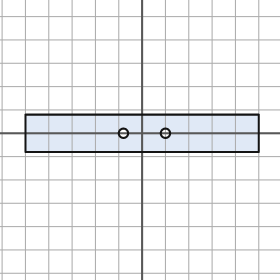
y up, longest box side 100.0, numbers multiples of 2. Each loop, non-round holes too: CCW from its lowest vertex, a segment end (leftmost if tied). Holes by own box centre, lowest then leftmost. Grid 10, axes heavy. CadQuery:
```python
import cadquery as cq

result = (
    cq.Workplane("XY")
    .moveTo(-50.0, -8.0)
    .lineTo(50.0, -8.0)
    .lineTo(50.0, 8.0)
    .lineTo(-50.0, 8.0)
    .close()
    .moveTo(-8.0, 0.0)
    .circle(2.0)
    .moveTo(10.0, 0.0)
    .circle(2.0)
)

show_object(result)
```